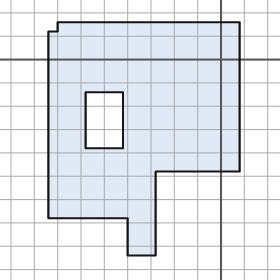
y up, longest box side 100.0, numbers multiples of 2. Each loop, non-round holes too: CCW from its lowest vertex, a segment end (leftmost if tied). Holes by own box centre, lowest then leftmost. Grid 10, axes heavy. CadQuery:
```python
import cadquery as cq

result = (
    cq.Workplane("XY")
    .moveTo(-40.0, -84.0)
    .lineTo(-28.0, -84.0)
    .lineTo(-28.0, -48.0)
    .lineTo(8.0, -48.0)
    .lineTo(8.0, 16.0)
    .lineTo(-70.0, 16.0)
    .lineTo(-70.0, 12.0)
    .lineTo(-74.0, 12.0)
    .lineTo(-74.0, -68.0)
    .lineTo(-40.0, -68.0)
    .close()
    .moveTo(-58.0, -38.0)
    .lineTo(-42.0, -38.0)
    .lineTo(-42.0, -14.0)
    .lineTo(-58.0, -14.0)
    .close()
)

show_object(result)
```